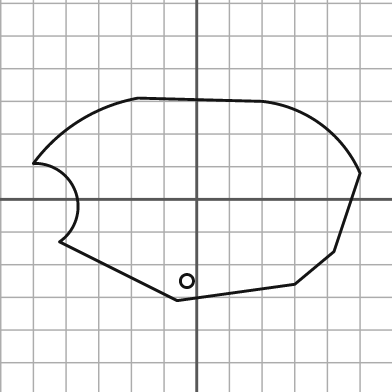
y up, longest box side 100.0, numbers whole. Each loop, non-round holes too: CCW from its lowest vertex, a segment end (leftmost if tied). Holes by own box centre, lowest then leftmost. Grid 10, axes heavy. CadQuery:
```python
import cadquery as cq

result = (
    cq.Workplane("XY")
    .moveTo(-6.0, -31.0)
    .lineTo(30.0, -26.0)
    .lineTo(42.0, -16.0)
    .lineTo(50.0, 8.0)
    .threePointArc((38.0, 23.0), (20.0, 30.0))
    .lineTo(-18.0, 31.0)
    .threePointArc((-36.0, 24.0), (-50.0, 11.0))
    .threePointArc((-37.0, 2.0), (-42.0, -13.0))
    .close()
    .moveTo(-3.0, -25.0)
    .circle(2.0)
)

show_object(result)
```